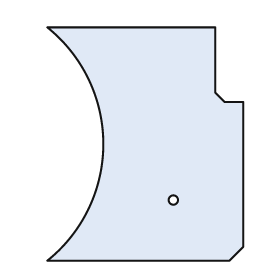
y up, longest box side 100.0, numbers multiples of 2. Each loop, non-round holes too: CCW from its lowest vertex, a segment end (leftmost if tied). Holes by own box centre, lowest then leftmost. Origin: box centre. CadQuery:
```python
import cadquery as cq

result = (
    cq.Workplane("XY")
    .moveTo(-42.0, -50.0)
    .lineTo(36.0, -50.0)
    .lineTo(42.0, -44.0)
    .lineTo(42.0, 18.0)
    .lineTo(34.0, 18.0)
    .lineTo(30.0, 22.0)
    .lineTo(30.0, 50.0)
    .lineTo(-42.0, 50.0)
    .threePointArc((-18.0, 0.0), (-42.0, -50.0))
    .close()
    .moveTo(12.0, -24.0)
    .circle(2.0)
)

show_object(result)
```